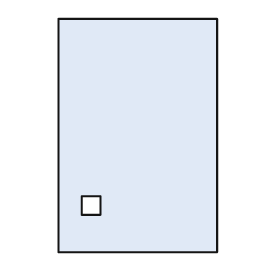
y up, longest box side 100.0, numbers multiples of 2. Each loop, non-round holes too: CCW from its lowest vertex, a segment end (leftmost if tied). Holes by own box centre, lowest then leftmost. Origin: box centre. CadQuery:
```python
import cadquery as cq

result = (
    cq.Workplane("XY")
    .moveTo(-34.0, -50.0)
    .lineTo(34.0, -50.0)
    .lineTo(34.0, 50.0)
    .lineTo(-34.0, 50.0)
    .close()
    .moveTo(-24.0, -34.0)
    .lineTo(-16.0, -34.0)
    .lineTo(-16.0, -26.0)
    .lineTo(-24.0, -26.0)
    .close()
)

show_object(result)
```